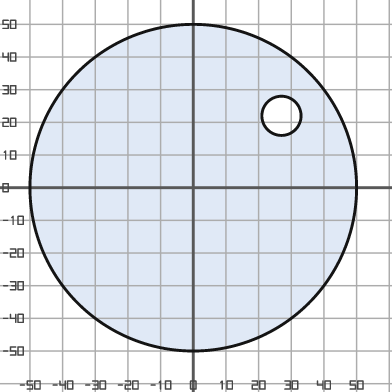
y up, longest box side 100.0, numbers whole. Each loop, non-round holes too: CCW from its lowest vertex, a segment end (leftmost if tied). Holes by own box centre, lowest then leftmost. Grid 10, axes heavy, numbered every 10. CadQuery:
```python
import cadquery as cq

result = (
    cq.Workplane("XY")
    .moveTo(0.0, 0.0)
    .circle(50.0)
    .moveTo(27.0, 22.0)
    .circle(6.0)
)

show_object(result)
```